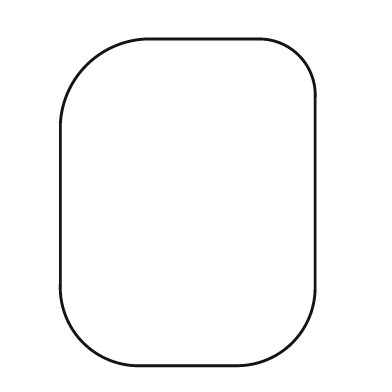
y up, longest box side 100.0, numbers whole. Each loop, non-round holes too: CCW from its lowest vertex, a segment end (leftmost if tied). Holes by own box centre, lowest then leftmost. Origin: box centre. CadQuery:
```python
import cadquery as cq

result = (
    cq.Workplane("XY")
    .moveTo(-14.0, -50.0)
    .lineTo(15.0, -50.0)
    .threePointArc((32.0, -43.0), (39.0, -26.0))
    .lineTo(39.0, 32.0)
    .threePointArc((34.0, 45.0), (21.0, 50.0))
    .lineTo(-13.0, 50.0)
    .threePointArc((-31.0, 42.0), (-39.0, 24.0))
    .lineTo(-39.0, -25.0)
    .threePointArc((-32.0, -43.0), (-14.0, -50.0))
    .close()
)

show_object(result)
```